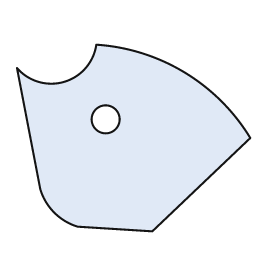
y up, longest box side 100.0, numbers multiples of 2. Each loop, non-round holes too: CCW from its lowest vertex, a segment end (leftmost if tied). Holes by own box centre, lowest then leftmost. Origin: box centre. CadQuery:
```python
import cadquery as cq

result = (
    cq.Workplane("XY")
    .moveTo(8.0, -40.0)
    .lineTo(50.0, 0.0)
    .threePointArc((22.0, 28.0), (-16.0, 40.0))
    .threePointArc((-30.0, 24.0), (-50.0, 30.0))
    .lineTo(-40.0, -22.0)
    .threePointArc((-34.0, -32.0), (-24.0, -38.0))
    .close()
    .moveTo(-12.0, 8.0)
    .circle(6.0)
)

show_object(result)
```